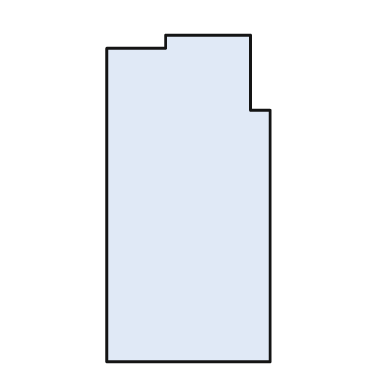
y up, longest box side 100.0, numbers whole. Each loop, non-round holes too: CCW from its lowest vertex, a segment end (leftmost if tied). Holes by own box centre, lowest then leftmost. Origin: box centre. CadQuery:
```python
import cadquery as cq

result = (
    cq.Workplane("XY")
    .moveTo(-25.0, -50.0)
    .lineTo(25.0, -50.0)
    .lineTo(25.0, 27.0)
    .lineTo(19.0, 27.0)
    .lineTo(19.0, 50.0)
    .lineTo(-7.0, 50.0)
    .lineTo(-7.0, 46.0)
    .lineTo(-25.0, 46.0)
    .close()
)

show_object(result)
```